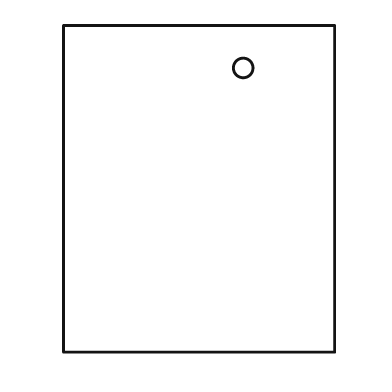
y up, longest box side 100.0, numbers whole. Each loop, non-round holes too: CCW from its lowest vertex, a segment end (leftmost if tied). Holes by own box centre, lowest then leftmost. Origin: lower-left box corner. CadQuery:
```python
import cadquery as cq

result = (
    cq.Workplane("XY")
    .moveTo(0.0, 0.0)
    .lineTo(83.0, 0.0)
    .lineTo(83.0, 100.0)
    .lineTo(0.0, 100.0)
    .close()
    .moveTo(55.0, 87.0)
    .circle(3.0)
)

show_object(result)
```